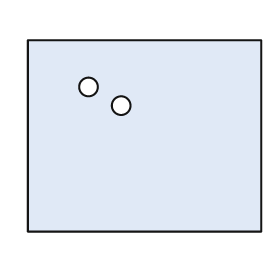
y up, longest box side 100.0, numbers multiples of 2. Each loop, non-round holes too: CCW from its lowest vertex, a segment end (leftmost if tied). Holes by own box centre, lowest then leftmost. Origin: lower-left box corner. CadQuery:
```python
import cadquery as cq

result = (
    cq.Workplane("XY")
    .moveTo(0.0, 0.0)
    .lineTo(100.0, 0.0)
    .lineTo(100.0, 82.0)
    .lineTo(0.0, 82.0)
    .close()
    .moveTo(40.0, 54.0)
    .circle(4.0)
    .moveTo(26.0, 62.0)
    .circle(4.0)
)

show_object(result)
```